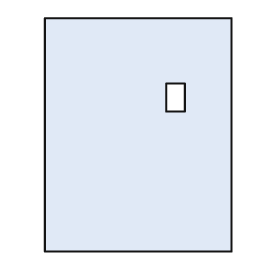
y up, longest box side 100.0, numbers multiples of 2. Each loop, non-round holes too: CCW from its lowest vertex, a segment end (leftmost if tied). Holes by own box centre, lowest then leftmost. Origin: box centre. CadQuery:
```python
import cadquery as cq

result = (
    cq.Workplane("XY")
    .moveTo(-40.0, -50.0)
    .lineTo(40.0, -50.0)
    .lineTo(40.0, 50.0)
    .lineTo(-40.0, 50.0)
    .close()
    .moveTo(12.0, 10.0)
    .lineTo(20.0, 10.0)
    .lineTo(20.0, 22.0)
    .lineTo(12.0, 22.0)
    .close()
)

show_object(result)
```